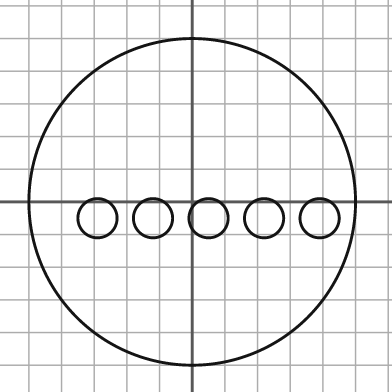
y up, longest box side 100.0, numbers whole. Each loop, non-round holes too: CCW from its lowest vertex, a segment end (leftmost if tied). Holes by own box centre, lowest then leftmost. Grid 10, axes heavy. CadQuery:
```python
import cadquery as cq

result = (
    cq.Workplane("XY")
    .moveTo(0.0, 0.0)
    .circle(50.0)
    .moveTo(-29.0, -5.0)
    .circle(6.0)
    .moveTo(-12.0, -5.0)
    .circle(6.0)
    .moveTo(5.0, -5.0)
    .circle(6.0)
    .moveTo(22.0, -5.0)
    .circle(6.0)
    .moveTo(39.0, -5.0)
    .circle(6.0)
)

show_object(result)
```